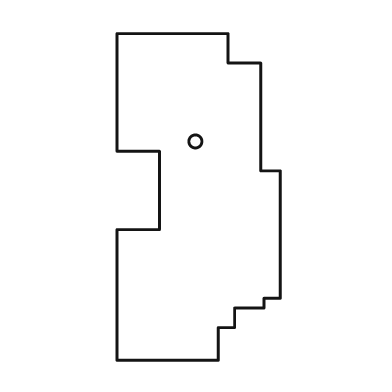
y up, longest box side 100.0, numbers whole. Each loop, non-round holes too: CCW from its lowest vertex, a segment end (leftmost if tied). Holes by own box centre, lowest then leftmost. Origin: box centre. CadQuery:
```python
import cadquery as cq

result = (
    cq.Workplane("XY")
    .moveTo(-25.0, -50.0)
    .lineTo(6.0, -50.0)
    .lineTo(6.0, -40.0)
    .lineTo(11.0, -40.0)
    .lineTo(11.0, -34.0)
    .lineTo(20.0, -34.0)
    .lineTo(20.0, -31.0)
    .lineTo(25.0, -31.0)
    .lineTo(25.0, 8.0)
    .lineTo(19.0, 8.0)
    .lineTo(19.0, 41.0)
    .lineTo(9.0, 41.0)
    .lineTo(9.0, 50.0)
    .lineTo(-25.0, 50.0)
    .lineTo(-25.0, 14.0)
    .lineTo(-12.0, 14.0)
    .lineTo(-12.0, -10.0)
    .lineTo(-25.0, -10.0)
    .close()
    .moveTo(-1.0, 17.0)
    .circle(2.0)
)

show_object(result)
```